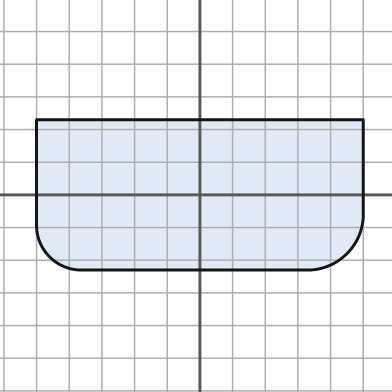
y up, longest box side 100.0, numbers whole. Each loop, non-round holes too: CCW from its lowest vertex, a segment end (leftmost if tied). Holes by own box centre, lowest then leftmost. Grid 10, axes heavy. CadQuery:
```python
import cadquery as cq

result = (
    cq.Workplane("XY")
    .moveTo(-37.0, -23.0)
    .lineTo(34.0, -23.0)
    .threePointArc((45.0, -18.0), (50.0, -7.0))
    .lineTo(50.0, 23.0)
    .lineTo(-50.0, 23.0)
    .lineTo(-50.0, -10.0)
    .threePointArc((-46.0, -19.0), (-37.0, -23.0))
    .close()
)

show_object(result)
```